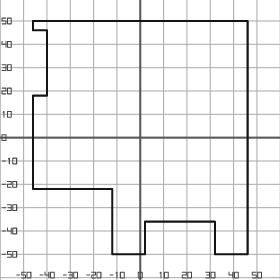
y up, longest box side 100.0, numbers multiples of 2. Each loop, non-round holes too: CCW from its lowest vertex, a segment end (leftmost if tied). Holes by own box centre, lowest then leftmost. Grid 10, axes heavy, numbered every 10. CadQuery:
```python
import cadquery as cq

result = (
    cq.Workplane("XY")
    .moveTo(-12.0, -50.0)
    .lineTo(2.0, -50.0)
    .lineTo(2.0, -36.0)
    .lineTo(32.0, -36.0)
    .lineTo(32.0, -50.0)
    .lineTo(46.0, -50.0)
    .lineTo(46.0, 50.0)
    .lineTo(-46.0, 50.0)
    .lineTo(-46.0, 46.0)
    .lineTo(-40.0, 46.0)
    .lineTo(-40.0, 18.0)
    .lineTo(-46.0, 18.0)
    .lineTo(-46.0, -22.0)
    .lineTo(-12.0, -22.0)
    .close()
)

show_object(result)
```